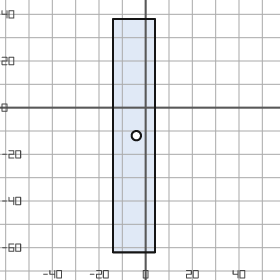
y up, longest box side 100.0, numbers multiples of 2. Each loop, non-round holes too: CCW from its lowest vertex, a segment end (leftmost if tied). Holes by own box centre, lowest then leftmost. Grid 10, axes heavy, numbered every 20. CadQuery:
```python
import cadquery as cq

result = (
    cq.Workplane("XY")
    .moveTo(-14.0, -62.0)
    .lineTo(4.0, -62.0)
    .lineTo(4.0, 38.0)
    .lineTo(-14.0, 38.0)
    .close()
    .moveTo(-4.0, -12.0)
    .circle(2.0)
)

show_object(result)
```